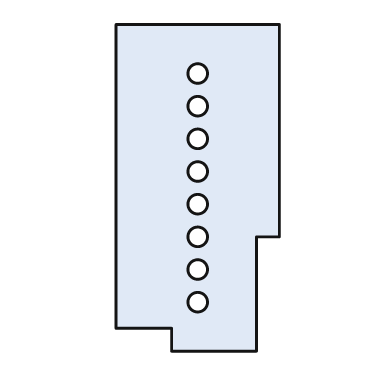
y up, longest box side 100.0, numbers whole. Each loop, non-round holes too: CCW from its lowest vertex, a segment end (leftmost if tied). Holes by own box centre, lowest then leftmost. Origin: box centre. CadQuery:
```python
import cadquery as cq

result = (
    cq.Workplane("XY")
    .moveTo(-8.0, -50.0)
    .lineTo(18.0, -50.0)
    .lineTo(18.0, -15.0)
    .lineTo(25.0, -15.0)
    .lineTo(25.0, 50.0)
    .lineTo(-25.0, 50.0)
    .lineTo(-25.0, -43.0)
    .lineTo(-8.0, -43.0)
    .close()
    .moveTo(0.0, -35.0)
    .circle(3.0)
    .moveTo(0.0, -25.0)
    .circle(3.0)
    .moveTo(0.0, -15.0)
    .circle(3.0)
    .moveTo(0.0, -5.0)
    .circle(3.0)
    .moveTo(0.0, 5.0)
    .circle(3.0)
    .moveTo(0.0, 15.0)
    .circle(3.0)
    .moveTo(0.0, 25.0)
    .circle(3.0)
    .moveTo(0.0, 35.0)
    .circle(3.0)
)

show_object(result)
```